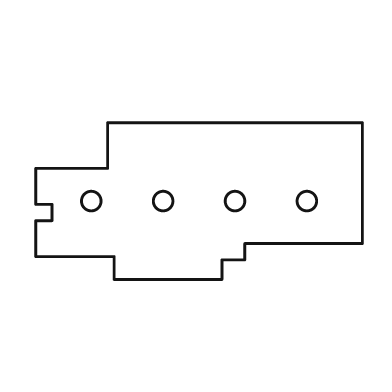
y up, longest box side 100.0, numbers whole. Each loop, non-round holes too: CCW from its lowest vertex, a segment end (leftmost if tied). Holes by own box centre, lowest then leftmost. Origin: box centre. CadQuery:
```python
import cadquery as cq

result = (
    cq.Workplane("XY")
    .moveTo(-26.0, -24.0)
    .lineTo(7.0, -24.0)
    .lineTo(7.0, -18.0)
    .lineTo(14.0, -18.0)
    .lineTo(14.0, -13.0)
    .lineTo(50.0, -13.0)
    .lineTo(50.0, 24.0)
    .lineTo(-28.0, 24.0)
    .lineTo(-28.0, 10.0)
    .lineTo(-50.0, 10.0)
    .lineTo(-50.0, -1.0)
    .lineTo(-45.0, -1.0)
    .lineTo(-45.0, -6.0)
    .lineTo(-50.0, -6.0)
    .lineTo(-50.0, -17.0)
    .lineTo(-26.0, -17.0)
    .close()
    .moveTo(-33.0, 0.0)
    .circle(3.0)
    .moveTo(-11.0, 0.0)
    .circle(3.0)
    .moveTo(11.0, 0.0)
    .circle(3.0)
    .moveTo(33.0, 0.0)
    .circle(3.0)
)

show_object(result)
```